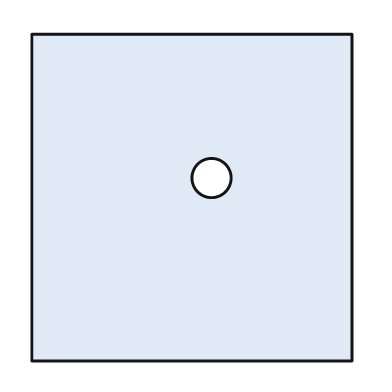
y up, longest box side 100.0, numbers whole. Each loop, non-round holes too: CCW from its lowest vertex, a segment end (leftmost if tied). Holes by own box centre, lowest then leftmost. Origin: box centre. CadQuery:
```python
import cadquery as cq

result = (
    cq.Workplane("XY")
    .moveTo(-49.0, -50.0)
    .lineTo(49.0, -50.0)
    .lineTo(49.0, 50.0)
    .lineTo(-49.0, 50.0)
    .close()
    .moveTo(6.0, 6.0)
    .circle(6.0)
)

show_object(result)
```